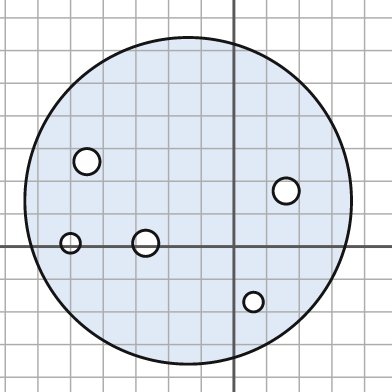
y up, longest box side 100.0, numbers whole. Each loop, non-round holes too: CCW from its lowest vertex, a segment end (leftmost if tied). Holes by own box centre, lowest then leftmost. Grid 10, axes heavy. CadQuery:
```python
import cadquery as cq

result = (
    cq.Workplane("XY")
    .moveTo(-14.0, 14.0)
    .circle(50.0)
    .moveTo(6.0, -17.0)
    .circle(3.0)
    .moveTo(-50.0, 1.0)
    .circle(3.0)
    .moveTo(-27.0, 1.0)
    .circle(4.0)
    .moveTo(16.0, 17.0)
    .circle(4.0)
    .moveTo(-45.0, 26.0)
    .circle(4.0)
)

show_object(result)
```